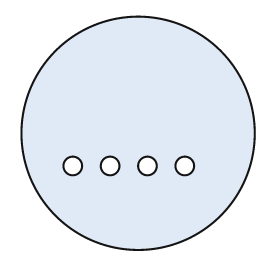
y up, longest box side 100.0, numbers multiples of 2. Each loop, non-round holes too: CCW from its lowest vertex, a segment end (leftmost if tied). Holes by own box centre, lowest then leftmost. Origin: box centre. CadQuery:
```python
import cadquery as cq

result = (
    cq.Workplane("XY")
    .moveTo(0.0, 0.0)
    .circle(50.0)
    .moveTo(-28.0, -14.0)
    .circle(4.0)
    .moveTo(-12.0, -14.0)
    .circle(4.0)
    .moveTo(4.0, -14.0)
    .circle(4.0)
    .moveTo(20.0, -14.0)
    .circle(4.0)
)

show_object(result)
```